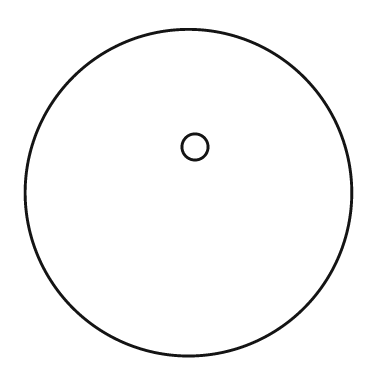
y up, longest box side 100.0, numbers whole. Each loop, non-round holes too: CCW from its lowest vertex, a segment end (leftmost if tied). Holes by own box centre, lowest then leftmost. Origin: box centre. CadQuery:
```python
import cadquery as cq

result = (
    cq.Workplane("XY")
    .moveTo(0.0, 0.0)
    .circle(50.0)
    .moveTo(2.0, 14.0)
    .circle(4.0)
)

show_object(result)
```